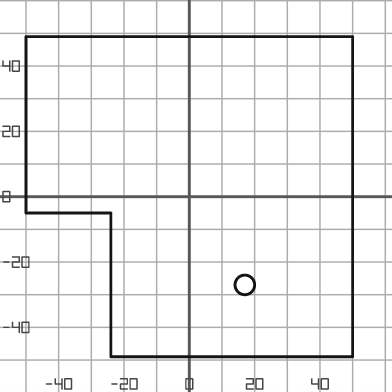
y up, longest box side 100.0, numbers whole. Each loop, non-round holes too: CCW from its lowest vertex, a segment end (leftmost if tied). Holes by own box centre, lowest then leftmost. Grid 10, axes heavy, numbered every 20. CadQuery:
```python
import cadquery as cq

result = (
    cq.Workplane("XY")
    .moveTo(-24.0, -49.0)
    .lineTo(50.0, -49.0)
    .lineTo(50.0, 49.0)
    .lineTo(-50.0, 49.0)
    .lineTo(-50.0, -5.0)
    .lineTo(-24.0, -5.0)
    .close()
    .moveTo(17.0, -27.0)
    .circle(3.0)
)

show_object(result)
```